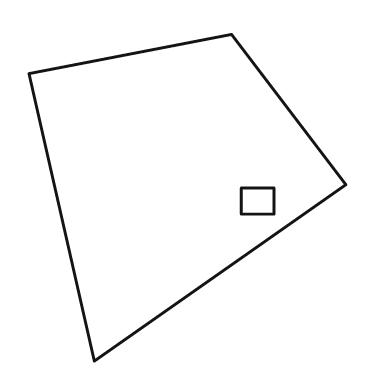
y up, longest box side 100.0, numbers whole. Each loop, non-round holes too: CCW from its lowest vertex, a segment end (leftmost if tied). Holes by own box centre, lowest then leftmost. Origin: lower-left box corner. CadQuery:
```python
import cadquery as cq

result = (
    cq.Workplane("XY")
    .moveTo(20.0, 0.0)
    .lineTo(97.0, 54.0)
    .lineTo(62.0, 100.0)
    .lineTo(0.0, 88.0)
    .close()
    .moveTo(65.0, 45.0)
    .lineTo(75.0, 45.0)
    .lineTo(75.0, 53.0)
    .lineTo(65.0, 53.0)
    .close()
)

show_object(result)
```